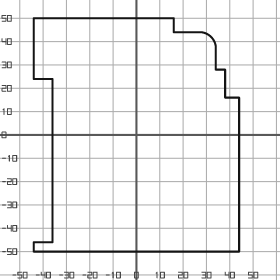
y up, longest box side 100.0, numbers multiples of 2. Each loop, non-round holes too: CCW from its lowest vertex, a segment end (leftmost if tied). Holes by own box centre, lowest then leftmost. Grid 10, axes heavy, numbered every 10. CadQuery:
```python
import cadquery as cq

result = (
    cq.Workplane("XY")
    .moveTo(-44.0, -50.0)
    .lineTo(44.0, -50.0)
    .lineTo(44.0, 16.0)
    .lineTo(38.0, 16.0)
    .lineTo(38.0, 28.0)
    .lineTo(34.0, 28.0)
    .lineTo(34.0, 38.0)
    .threePointArc((32.0, 42.0), (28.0, 44.0))
    .lineTo(16.0, 44.0)
    .lineTo(16.0, 50.0)
    .lineTo(-44.0, 50.0)
    .lineTo(-44.0, 24.0)
    .lineTo(-36.0, 24.0)
    .lineTo(-36.0, -46.0)
    .lineTo(-44.0, -46.0)
    .close()
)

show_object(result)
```